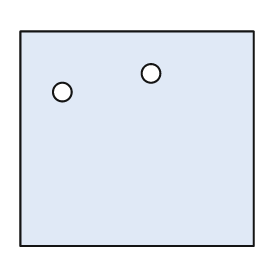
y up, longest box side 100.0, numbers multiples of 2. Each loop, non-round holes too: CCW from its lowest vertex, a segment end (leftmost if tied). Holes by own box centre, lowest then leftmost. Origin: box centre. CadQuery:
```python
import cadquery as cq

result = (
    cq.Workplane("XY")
    .moveTo(-50.0, -46.0)
    .lineTo(50.0, -46.0)
    .lineTo(50.0, 46.0)
    .lineTo(-50.0, 46.0)
    .close()
    .moveTo(-32.0, 20.0)
    .circle(4.0)
    .moveTo(6.0, 28.0)
    .circle(4.0)
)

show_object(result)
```